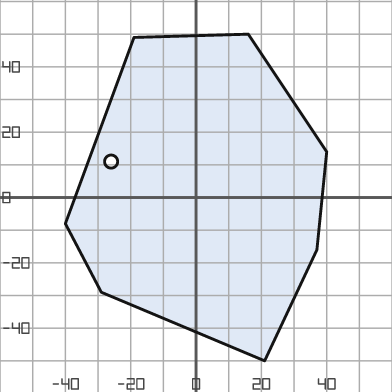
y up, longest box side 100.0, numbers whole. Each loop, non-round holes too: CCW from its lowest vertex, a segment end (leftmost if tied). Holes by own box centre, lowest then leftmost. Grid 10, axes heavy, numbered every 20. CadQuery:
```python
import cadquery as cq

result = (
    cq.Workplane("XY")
    .moveTo(21.0, -50.0)
    .lineTo(37.0, -16.0)
    .lineTo(40.0, 14.0)
    .lineTo(16.0, 50.0)
    .lineTo(-19.0, 49.0)
    .lineTo(-40.0, -8.0)
    .lineTo(-29.0, -29.0)
    .close()
    .moveTo(-26.0, 11.0)
    .circle(2.0)
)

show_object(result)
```